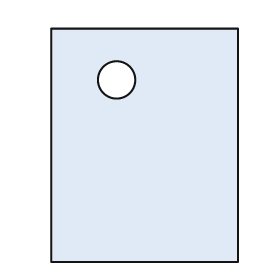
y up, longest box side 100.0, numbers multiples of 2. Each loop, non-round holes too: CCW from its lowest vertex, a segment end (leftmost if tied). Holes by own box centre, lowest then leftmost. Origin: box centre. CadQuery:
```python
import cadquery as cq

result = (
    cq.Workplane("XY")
    .moveTo(-40.0, -50.0)
    .lineTo(40.0, -50.0)
    .lineTo(40.0, 50.0)
    .lineTo(-40.0, 50.0)
    .close()
    .moveTo(-12.0, 28.0)
    .circle(8.0)
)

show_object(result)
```